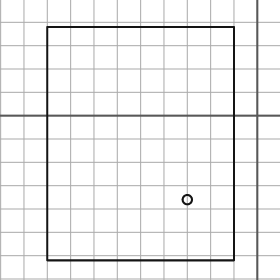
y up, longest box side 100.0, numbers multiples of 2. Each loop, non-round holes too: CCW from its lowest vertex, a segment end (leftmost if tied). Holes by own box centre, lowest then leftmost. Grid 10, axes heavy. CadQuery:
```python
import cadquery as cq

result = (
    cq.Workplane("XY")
    .moveTo(-90.0, -62.0)
    .lineTo(-10.0, -62.0)
    .lineTo(-10.0, 38.0)
    .lineTo(-90.0, 38.0)
    .close()
    .moveTo(-30.0, -36.0)
    .circle(2.0)
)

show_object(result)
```